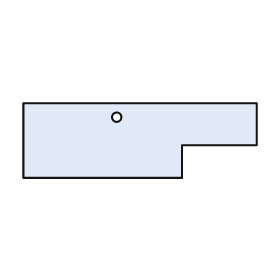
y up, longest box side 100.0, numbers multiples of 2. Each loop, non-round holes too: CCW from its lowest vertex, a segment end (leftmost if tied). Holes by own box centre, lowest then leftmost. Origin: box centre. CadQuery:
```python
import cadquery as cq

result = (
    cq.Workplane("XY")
    .moveTo(-50.0, -16.0)
    .lineTo(18.0, -16.0)
    .lineTo(18.0, -2.0)
    .lineTo(50.0, -2.0)
    .lineTo(50.0, 16.0)
    .lineTo(-50.0, 16.0)
    .close()
    .moveTo(-10.0, 10.0)
    .circle(2.0)
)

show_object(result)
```